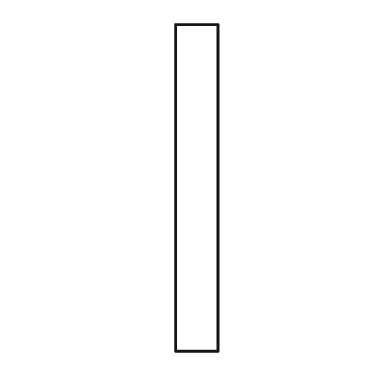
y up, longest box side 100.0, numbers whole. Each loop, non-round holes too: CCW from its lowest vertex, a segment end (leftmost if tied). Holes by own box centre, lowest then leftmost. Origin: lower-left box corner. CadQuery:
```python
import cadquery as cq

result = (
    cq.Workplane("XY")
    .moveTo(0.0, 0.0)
    .lineTo(13.0, 0.0)
    .lineTo(13.0, 100.0)
    .lineTo(0.0, 100.0)
    .close()
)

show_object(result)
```